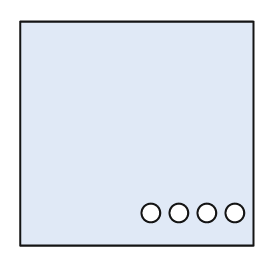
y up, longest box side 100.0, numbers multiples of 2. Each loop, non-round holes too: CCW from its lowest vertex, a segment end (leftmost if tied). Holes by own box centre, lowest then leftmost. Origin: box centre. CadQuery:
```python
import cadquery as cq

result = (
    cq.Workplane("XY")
    .moveTo(-50.0, -48.0)
    .lineTo(50.0, -48.0)
    .lineTo(50.0, 48.0)
    .lineTo(-50.0, 48.0)
    .close()
    .moveTo(6.0, -34.0)
    .circle(4.0)
    .moveTo(18.0, -34.0)
    .circle(4.0)
    .moveTo(30.0, -34.0)
    .circle(4.0)
    .moveTo(42.0, -34.0)
    .circle(4.0)
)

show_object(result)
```